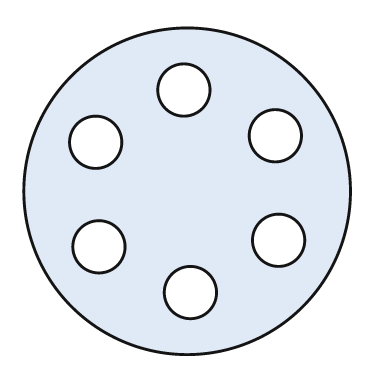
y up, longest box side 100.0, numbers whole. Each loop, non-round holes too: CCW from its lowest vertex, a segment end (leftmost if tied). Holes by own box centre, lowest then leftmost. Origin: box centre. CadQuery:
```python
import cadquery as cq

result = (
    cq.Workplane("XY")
    .moveTo(0.0, 0.0)
    .circle(50.0)
    .moveTo(1.0, -31.0)
    .circle(8.0)
    .moveTo(-27.0, -17.0)
    .circle(8.0)
    .moveTo(28.0, -15.0)
    .circle(8.0)
    .moveTo(-28.0, 15.0)
    .circle(8.0)
    .moveTo(27.0, 17.0)
    .circle(8.0)
    .moveTo(-1.0, 31.0)
    .circle(8.0)
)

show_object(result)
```